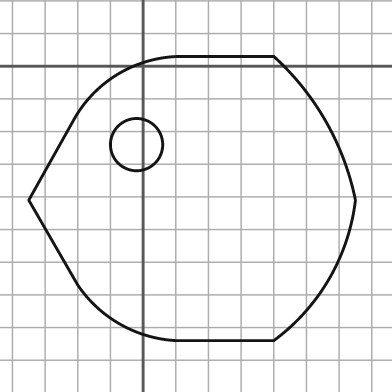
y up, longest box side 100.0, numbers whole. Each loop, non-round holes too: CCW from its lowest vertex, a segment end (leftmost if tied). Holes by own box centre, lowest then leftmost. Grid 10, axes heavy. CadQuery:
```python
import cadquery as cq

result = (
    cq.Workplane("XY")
    .moveTo(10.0, -84.0)
    .lineTo(40.0, -84.0)
    .threePointArc((57.0, -65.0), (65.0, -41.0))
    .threePointArc((56.0, -17.0), (40.0, 3.0))
    .lineTo(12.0, 3.0)
    .threePointArc((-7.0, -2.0), (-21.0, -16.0))
    .lineTo(-35.0, -41.0)
    .lineTo(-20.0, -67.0)
    .threePointArc((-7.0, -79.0), (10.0, -84.0))
    .close()
    .moveTo(-2.0, -24.0)
    .circle(8.0)
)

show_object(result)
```